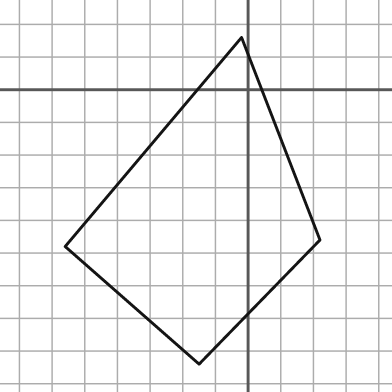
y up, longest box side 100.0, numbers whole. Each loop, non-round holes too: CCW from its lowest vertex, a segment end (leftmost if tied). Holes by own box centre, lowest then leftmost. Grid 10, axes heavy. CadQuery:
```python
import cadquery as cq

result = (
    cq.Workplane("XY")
    .moveTo(-15.0, -84.0)
    .lineTo(22.0, -46.0)
    .lineTo(-2.0, 16.0)
    .lineTo(-56.0, -48.0)
    .close()
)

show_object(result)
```